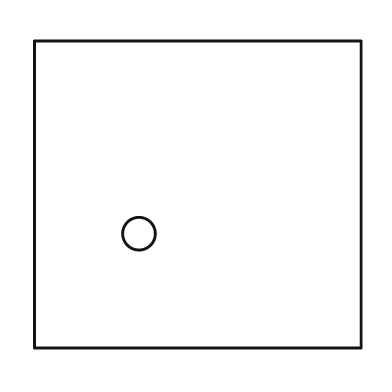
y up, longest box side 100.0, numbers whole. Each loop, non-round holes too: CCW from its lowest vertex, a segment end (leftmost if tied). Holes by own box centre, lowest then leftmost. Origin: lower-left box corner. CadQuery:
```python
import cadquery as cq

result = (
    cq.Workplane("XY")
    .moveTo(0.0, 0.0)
    .lineTo(100.0, 0.0)
    .lineTo(100.0, 94.0)
    .lineTo(0.0, 94.0)
    .close()
    .moveTo(32.0, 35.0)
    .circle(5.0)
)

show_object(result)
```